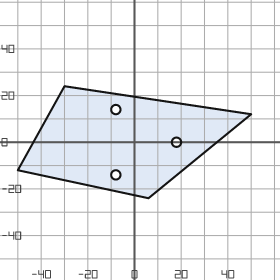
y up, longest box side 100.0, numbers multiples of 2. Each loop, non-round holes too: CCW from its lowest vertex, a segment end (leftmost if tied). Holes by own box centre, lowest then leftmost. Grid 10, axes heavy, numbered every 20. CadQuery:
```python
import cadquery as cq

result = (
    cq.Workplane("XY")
    .moveTo(6.0, -24.0)
    .lineTo(50.0, 12.0)
    .lineTo(-30.0, 24.0)
    .lineTo(-50.0, -12.0)
    .close()
    .moveTo(-8.0, -14.0)
    .circle(2.0)
    .moveTo(18.0, 0.0)
    .circle(2.0)
    .moveTo(-8.0, 14.0)
    .circle(2.0)
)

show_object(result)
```